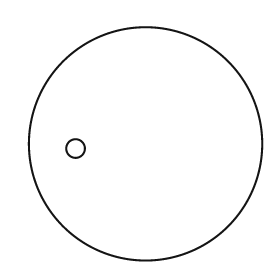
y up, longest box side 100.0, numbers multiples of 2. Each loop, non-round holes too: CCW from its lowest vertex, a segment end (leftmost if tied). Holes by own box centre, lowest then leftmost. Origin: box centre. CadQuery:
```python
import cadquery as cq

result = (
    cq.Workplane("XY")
    .moveTo(0.0, 0.0)
    .circle(50.0)
    .moveTo(-30.0, -2.0)
    .circle(4.0)
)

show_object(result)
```